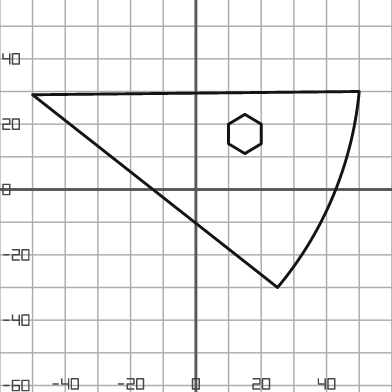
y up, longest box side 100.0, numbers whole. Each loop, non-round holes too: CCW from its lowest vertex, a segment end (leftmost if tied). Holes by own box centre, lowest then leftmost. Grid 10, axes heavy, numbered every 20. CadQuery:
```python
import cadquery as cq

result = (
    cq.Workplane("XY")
    .moveTo(25.0, -30.0)
    .threePointArc((42.0, -2.0), (50.0, 30.0))
    .lineTo(-50.0, 29.0)
    .close()
    .moveTo(15.0, 11.0)
    .lineTo(20.0, 14.0)
    .lineTo(20.0, 20.0)
    .lineTo(15.0, 23.0)
    .lineTo(10.0, 20.0)
    .lineTo(10.0, 14.0)
    .close()
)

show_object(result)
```